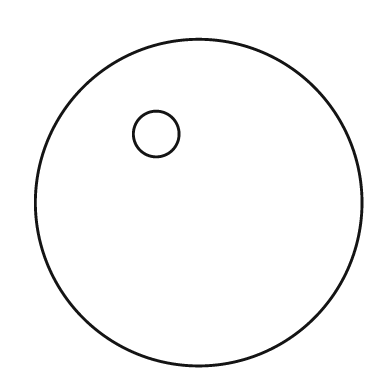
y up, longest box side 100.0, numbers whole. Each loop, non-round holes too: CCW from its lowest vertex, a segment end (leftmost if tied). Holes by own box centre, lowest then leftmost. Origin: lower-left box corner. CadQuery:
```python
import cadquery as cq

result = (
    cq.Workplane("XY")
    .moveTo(50.0, 50.0)
    .circle(50.0)
    .moveTo(37.0, 71.0)
    .circle(7.0)
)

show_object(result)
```